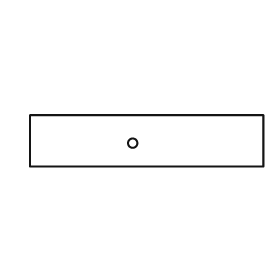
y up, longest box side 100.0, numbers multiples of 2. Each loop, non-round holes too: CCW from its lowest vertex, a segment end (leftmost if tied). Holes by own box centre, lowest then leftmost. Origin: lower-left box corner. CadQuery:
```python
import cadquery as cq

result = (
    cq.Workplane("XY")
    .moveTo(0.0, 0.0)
    .lineTo(100.0, 0.0)
    .lineTo(100.0, 22.0)
    .lineTo(0.0, 22.0)
    .close()
    .moveTo(44.0, 10.0)
    .circle(2.0)
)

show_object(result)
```